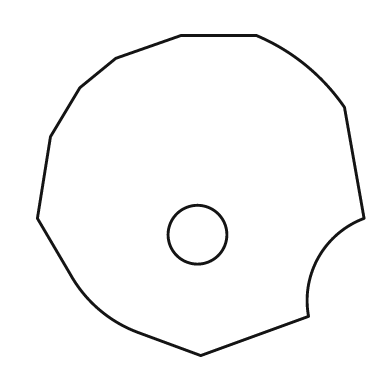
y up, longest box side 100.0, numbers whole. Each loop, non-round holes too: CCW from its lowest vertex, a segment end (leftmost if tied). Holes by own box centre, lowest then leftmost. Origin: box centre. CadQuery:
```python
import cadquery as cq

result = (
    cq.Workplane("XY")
    .moveTo(0.0, -49.0)
    .lineTo(33.0, -37.0)
    .threePointArc((36.0, -19.0), (50.0, -7.0))
    .lineTo(44.0, 27.0)
    .threePointArc((32.0, 40.0), (17.0, 49.0))
    .lineTo(-6.0, 49.0)
    .lineTo(-26.0, 42.0)
    .lineTo(-37.0, 33.0)
    .lineTo(-46.0, 18.0)
    .lineTo(-50.0, -7.0)
    .lineTo(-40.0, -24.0)
    .threePointArc((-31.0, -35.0), (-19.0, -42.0))
    .close()
    .moveTo(-1.0, -12.0)
    .circle(9.0)
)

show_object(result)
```